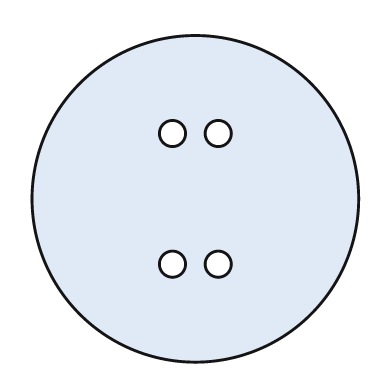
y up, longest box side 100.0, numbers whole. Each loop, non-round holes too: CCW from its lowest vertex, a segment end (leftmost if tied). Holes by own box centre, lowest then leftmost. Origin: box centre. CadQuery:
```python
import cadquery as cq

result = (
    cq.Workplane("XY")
    .moveTo(0.0, 0.0)
    .circle(50.0)
    .moveTo(-7.0, -20.0)
    .circle(4.0)
    .moveTo(7.0, -20.0)
    .circle(4.0)
    .moveTo(-7.0, 20.0)
    .circle(4.0)
    .moveTo(7.0, 20.0)
    .circle(4.0)
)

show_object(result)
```